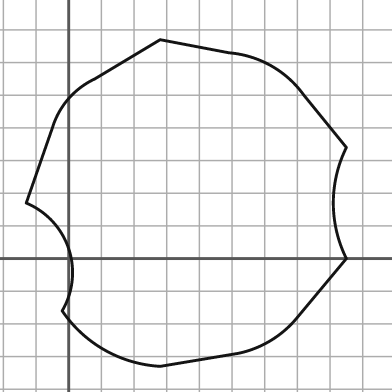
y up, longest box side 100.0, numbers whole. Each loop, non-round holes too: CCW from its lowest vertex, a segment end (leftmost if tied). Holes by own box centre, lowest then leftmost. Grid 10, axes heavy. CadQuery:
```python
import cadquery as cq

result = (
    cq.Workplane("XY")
    .moveTo(28.0, -33.0)
    .lineTo(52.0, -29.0)
    .threePointArc((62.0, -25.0), (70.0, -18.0))
    .lineTo(85.0, 0.0)
    .threePointArc((81.0, 17.0), (85.0, 34.0))
    .lineTo(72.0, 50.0)
    .threePointArc((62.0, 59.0), (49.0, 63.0))
    .lineTo(28.0, 67.0)
    .lineTo(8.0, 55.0)
    .threePointArc((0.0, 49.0), (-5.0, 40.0))
    .lineTo(-13.0, 17.0)
    .threePointArc((0.0, 3.0), (-2.0, -16.0))
    .threePointArc((11.0, -28.0), (28.0, -33.0))
    .close()
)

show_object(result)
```